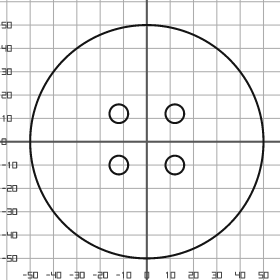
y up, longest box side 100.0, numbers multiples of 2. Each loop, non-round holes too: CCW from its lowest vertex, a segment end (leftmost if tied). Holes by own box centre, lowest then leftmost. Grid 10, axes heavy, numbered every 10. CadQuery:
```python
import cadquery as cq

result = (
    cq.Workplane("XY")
    .moveTo(0.0, 0.0)
    .circle(50.0)
    .moveTo(-12.0, -10.0)
    .circle(4.0)
    .moveTo(12.0, -10.0)
    .circle(4.0)
    .moveTo(-12.0, 12.0)
    .circle(4.0)
    .moveTo(12.0, 12.0)
    .circle(4.0)
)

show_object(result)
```